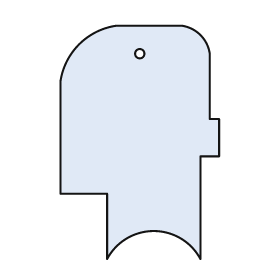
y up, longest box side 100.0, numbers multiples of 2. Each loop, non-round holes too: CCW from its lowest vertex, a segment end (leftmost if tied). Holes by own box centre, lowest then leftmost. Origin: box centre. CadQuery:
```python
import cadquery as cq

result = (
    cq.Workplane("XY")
    .moveTo(-14.0, -50.0)
    .threePointArc((6.0, -38.0), (26.0, -50.0))
    .lineTo(26.0, -6.0)
    .lineTo(34.0, -6.0)
    .lineTo(34.0, 10.0)
    .lineTo(30.0, 10.0)
    .lineTo(30.0, 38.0)
    .threePointArc((26.0, 46.0), (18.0, 50.0))
    .lineTo(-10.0, 50.0)
    .threePointArc((-26.0, 42.0), (-34.0, 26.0))
    .lineTo(-34.0, -22.0)
    .lineTo(-14.0, -22.0)
    .close()
    .moveTo(0.0, 38.0)
    .circle(2.0)
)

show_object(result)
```